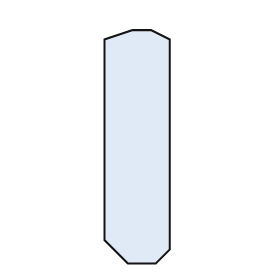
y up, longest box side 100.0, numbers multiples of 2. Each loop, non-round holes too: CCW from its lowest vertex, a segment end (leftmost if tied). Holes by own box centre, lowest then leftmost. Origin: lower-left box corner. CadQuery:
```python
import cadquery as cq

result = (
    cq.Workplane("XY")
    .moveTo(10.0, 0.0)
    .lineTo(22.0, 0.0)
    .lineTo(28.0, 6.0)
    .lineTo(28.0, 96.0)
    .lineTo(20.0, 100.0)
    .lineTo(12.0, 100.0)
    .lineTo(0.0, 96.0)
    .lineTo(0.0, 10.0)
    .close()
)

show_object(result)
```